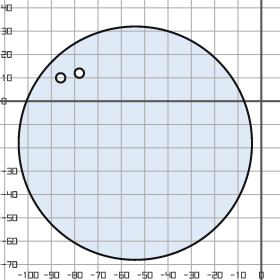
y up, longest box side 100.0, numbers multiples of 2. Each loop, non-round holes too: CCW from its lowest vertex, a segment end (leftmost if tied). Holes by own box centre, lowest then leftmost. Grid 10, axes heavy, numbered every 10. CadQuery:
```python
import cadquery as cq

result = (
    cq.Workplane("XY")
    .moveTo(-54.0, -18.0)
    .circle(50.0)
    .moveTo(-86.0, 10.0)
    .circle(2.0)
    .moveTo(-78.0, 12.0)
    .circle(2.0)
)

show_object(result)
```